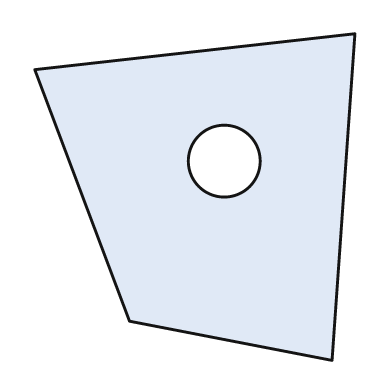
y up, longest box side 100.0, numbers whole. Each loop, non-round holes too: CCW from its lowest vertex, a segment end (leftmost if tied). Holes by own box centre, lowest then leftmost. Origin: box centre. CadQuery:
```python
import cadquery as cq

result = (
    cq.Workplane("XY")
    .moveTo(42.0, -50.0)
    .lineTo(49.0, 50.0)
    .lineTo(-49.0, 39.0)
    .lineTo(-20.0, -38.0)
    .close()
    .moveTo(9.0, 11.0)
    .circle(11.0)
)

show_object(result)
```